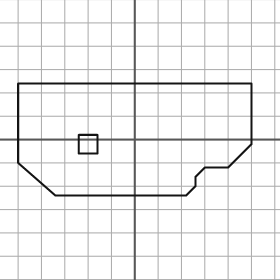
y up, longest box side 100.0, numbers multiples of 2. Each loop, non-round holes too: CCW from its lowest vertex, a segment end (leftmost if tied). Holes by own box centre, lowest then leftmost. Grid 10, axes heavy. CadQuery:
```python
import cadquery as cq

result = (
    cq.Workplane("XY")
    .moveTo(-34.0, -24.0)
    .lineTo(22.0, -24.0)
    .lineTo(26.0, -20.0)
    .lineTo(26.0, -16.0)
    .lineTo(30.0, -12.0)
    .lineTo(40.0, -12.0)
    .lineTo(50.0, -2.0)
    .lineTo(50.0, 24.0)
    .lineTo(-50.0, 24.0)
    .lineTo(-50.0, -10.0)
    .close()
    .moveTo(-24.0, -6.0)
    .lineTo(-16.0, -6.0)
    .lineTo(-16.0, 2.0)
    .lineTo(-24.0, 2.0)
    .close()
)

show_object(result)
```